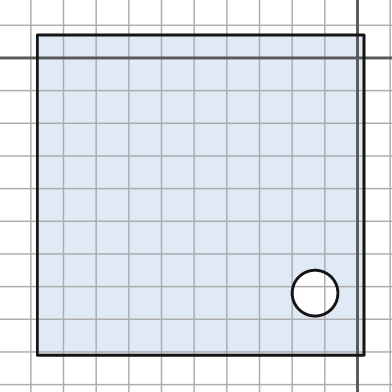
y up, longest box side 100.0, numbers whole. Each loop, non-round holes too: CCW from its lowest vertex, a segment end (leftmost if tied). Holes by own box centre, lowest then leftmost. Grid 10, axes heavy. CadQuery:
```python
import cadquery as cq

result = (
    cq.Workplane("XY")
    .moveTo(-98.0, -91.0)
    .lineTo(2.0, -91.0)
    .lineTo(2.0, 7.0)
    .lineTo(-98.0, 7.0)
    .close()
    .moveTo(-13.0, -72.0)
    .circle(7.0)
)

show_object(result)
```